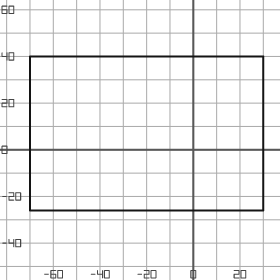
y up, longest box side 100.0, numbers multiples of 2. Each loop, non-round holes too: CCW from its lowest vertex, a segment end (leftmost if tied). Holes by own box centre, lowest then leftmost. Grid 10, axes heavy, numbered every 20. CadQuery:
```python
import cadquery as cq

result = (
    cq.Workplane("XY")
    .moveTo(-70.0, -26.0)
    .lineTo(30.0, -26.0)
    .lineTo(30.0, 40.0)
    .lineTo(-70.0, 40.0)
    .close()
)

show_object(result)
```